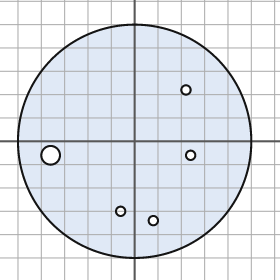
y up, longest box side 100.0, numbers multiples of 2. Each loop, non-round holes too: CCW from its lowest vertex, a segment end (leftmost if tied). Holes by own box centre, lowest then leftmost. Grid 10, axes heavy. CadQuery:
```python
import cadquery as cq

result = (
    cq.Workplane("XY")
    .moveTo(0.0, 0.0)
    .circle(50.0)
    .moveTo(8.0, -34.0)
    .circle(2.0)
    .moveTo(-6.0, -30.0)
    .circle(2.0)
    .moveTo(-36.0, -6.0)
    .circle(4.0)
    .moveTo(24.0, -6.0)
    .circle(2.0)
    .moveTo(22.0, 22.0)
    .circle(2.0)
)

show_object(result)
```